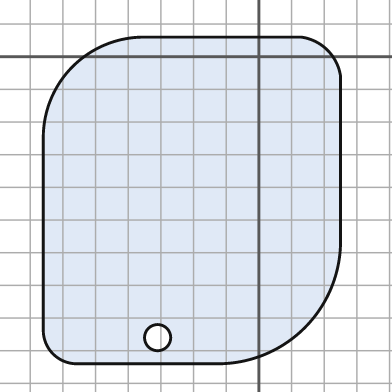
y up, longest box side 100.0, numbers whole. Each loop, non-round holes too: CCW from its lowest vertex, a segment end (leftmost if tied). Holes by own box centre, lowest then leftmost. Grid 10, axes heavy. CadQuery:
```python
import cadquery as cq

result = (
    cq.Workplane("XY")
    .moveTo(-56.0, -94.0)
    .lineTo(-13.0, -94.0)
    .threePointArc((14.0, -83.0), (25.0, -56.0))
    .lineTo(25.0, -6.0)
    .threePointArc((21.0, 2.0), (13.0, 6.0))
    .lineTo(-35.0, 6.0)
    .threePointArc((-57.0, -3.0), (-66.0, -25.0))
    .lineTo(-66.0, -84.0)
    .threePointArc((-63.0, -91.0), (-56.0, -94.0))
    .close()
    .moveTo(-31.0, -86.0)
    .circle(4.0)
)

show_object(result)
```